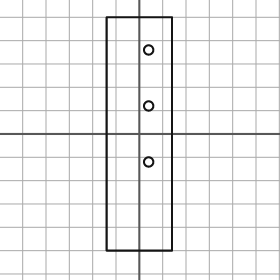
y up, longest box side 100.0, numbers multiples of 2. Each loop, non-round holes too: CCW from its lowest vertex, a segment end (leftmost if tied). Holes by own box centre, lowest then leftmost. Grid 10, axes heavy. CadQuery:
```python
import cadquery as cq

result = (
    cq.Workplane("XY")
    .moveTo(-14.0, -50.0)
    .lineTo(14.0, -50.0)
    .lineTo(14.0, 50.0)
    .lineTo(-14.0, 50.0)
    .close()
    .moveTo(4.0, -12.0)
    .circle(2.0)
    .moveTo(4.0, 12.0)
    .circle(2.0)
    .moveTo(4.0, 36.0)
    .circle(2.0)
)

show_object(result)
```